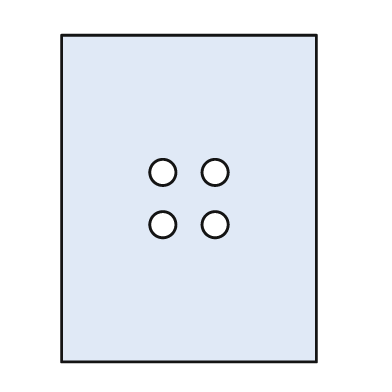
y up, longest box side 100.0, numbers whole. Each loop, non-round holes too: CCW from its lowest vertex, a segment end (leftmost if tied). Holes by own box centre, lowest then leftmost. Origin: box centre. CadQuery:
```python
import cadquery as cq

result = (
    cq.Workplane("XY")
    .moveTo(-39.0, -50.0)
    .lineTo(39.0, -50.0)
    .lineTo(39.0, 50.0)
    .lineTo(-39.0, 50.0)
    .close()
    .moveTo(-8.0, -8.0)
    .circle(4.0)
    .moveTo(8.0, -8.0)
    .circle(4.0)
    .moveTo(-8.0, 8.0)
    .circle(4.0)
    .moveTo(8.0, 8.0)
    .circle(4.0)
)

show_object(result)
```